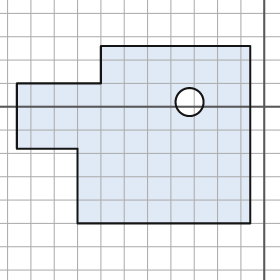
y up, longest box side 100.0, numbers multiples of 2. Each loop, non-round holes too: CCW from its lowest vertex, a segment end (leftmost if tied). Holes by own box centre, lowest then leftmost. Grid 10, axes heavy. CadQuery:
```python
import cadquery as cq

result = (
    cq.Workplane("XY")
    .moveTo(-80.0, -50.0)
    .lineTo(-6.0, -50.0)
    .lineTo(-6.0, 26.0)
    .lineTo(-70.0, 26.0)
    .lineTo(-70.0, 10.0)
    .lineTo(-106.0, 10.0)
    .lineTo(-106.0, -18.0)
    .lineTo(-80.0, -18.0)
    .close()
    .moveTo(-32.0, 2.0)
    .circle(6.0)
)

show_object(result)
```